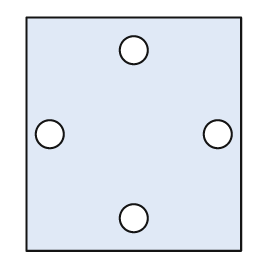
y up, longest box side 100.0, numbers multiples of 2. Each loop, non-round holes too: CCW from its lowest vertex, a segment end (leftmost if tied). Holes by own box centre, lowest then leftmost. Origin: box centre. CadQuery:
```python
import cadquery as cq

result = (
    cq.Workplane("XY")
    .moveTo(-46.0, -50.0)
    .lineTo(46.0, -50.0)
    .lineTo(46.0, 50.0)
    .lineTo(-46.0, 50.0)
    .close()
    .moveTo(0.0, -36.0)
    .circle(6.0)
    .moveTo(-36.0, 0.0)
    .circle(6.0)
    .moveTo(36.0, 0.0)
    .circle(6.0)
    .moveTo(0.0, 36.0)
    .circle(6.0)
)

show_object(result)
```